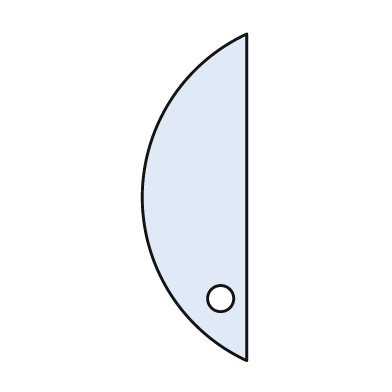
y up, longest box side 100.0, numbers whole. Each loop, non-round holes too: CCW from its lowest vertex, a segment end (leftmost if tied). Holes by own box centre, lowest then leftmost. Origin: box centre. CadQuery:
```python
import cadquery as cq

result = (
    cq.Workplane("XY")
    .moveTo(16.0, -50.0)
    .lineTo(16.0, 50.0)
    .threePointArc((-16.0, 0.0), (16.0, -50.0))
    .close()
    .moveTo(8.0, -31.0)
    .circle(4.0)
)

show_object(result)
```